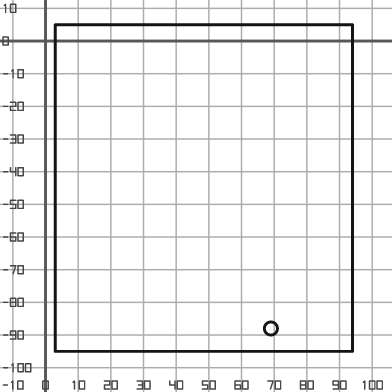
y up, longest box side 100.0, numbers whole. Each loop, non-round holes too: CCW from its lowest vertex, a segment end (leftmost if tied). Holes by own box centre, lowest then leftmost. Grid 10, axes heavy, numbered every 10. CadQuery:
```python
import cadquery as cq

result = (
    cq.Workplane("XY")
    .moveTo(3.0, -95.0)
    .lineTo(94.0, -95.0)
    .lineTo(94.0, 5.0)
    .lineTo(3.0, 5.0)
    .close()
    .moveTo(69.0, -88.0)
    .circle(2.0)
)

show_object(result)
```